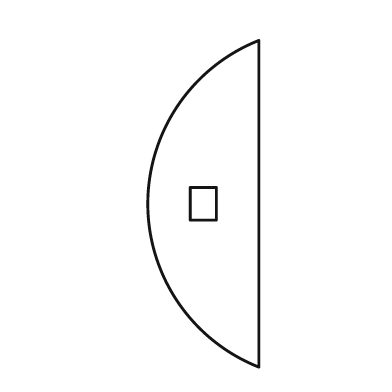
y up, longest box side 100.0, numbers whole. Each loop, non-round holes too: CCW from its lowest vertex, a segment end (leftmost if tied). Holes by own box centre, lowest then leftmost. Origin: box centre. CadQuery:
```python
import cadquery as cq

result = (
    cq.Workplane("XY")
    .moveTo(17.0, -50.0)
    .lineTo(17.0, 50.0)
    .threePointArc((-17.0, 0.0), (17.0, -50.0))
    .close()
    .moveTo(-4.0, -5.0)
    .lineTo(4.0, -5.0)
    .lineTo(4.0, 5.0)
    .lineTo(-4.0, 5.0)
    .close()
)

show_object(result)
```